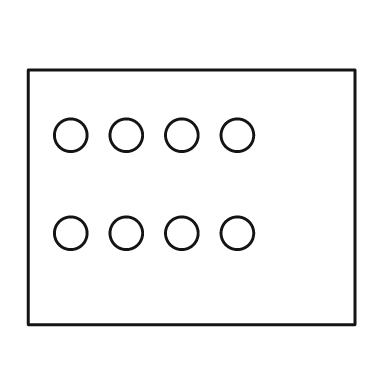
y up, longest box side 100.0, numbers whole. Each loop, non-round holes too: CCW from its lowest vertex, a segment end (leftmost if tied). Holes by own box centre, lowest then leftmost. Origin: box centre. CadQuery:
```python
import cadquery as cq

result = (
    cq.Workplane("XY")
    .moveTo(-50.0, -39.0)
    .lineTo(50.0, -39.0)
    .lineTo(50.0, 39.0)
    .lineTo(-50.0, 39.0)
    .close()
    .moveTo(-37.0, -11.0)
    .circle(5.0)
    .moveTo(-20.0, -11.0)
    .circle(5.0)
    .moveTo(-3.0, -11.0)
    .circle(5.0)
    .moveTo(14.0, -11.0)
    .circle(5.0)
    .moveTo(-37.0, 19.0)
    .circle(5.0)
    .moveTo(-20.0, 19.0)
    .circle(5.0)
    .moveTo(-3.0, 19.0)
    .circle(5.0)
    .moveTo(14.0, 19.0)
    .circle(5.0)
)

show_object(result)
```